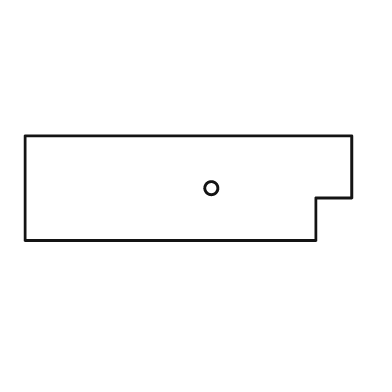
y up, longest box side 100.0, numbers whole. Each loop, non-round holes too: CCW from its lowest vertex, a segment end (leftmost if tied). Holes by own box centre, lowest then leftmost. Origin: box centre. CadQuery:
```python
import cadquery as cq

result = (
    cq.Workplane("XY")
    .moveTo(-50.0, -16.0)
    .lineTo(39.0, -16.0)
    .lineTo(39.0, -3.0)
    .lineTo(50.0, -3.0)
    .lineTo(50.0, 16.0)
    .lineTo(-50.0, 16.0)
    .close()
    .moveTo(7.0, 0.0)
    .circle(2.0)
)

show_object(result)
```